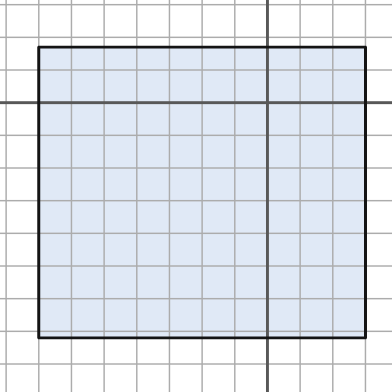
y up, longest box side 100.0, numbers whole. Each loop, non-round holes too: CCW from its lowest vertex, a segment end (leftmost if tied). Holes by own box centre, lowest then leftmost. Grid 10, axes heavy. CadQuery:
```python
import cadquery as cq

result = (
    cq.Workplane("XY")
    .moveTo(-70.0, -72.0)
    .lineTo(30.0, -72.0)
    .lineTo(30.0, 17.0)
    .lineTo(-70.0, 17.0)
    .close()
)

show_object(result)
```